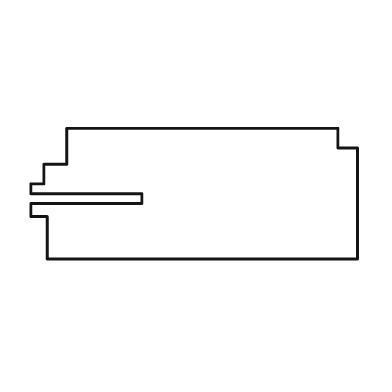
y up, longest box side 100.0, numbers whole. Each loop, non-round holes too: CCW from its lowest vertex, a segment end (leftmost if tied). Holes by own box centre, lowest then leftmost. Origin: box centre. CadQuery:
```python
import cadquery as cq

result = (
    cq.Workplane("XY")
    .moveTo(-45.0, -20.0)
    .lineTo(50.0, -20.0)
    .lineTo(50.0, 14.0)
    .lineTo(44.0, 14.0)
    .lineTo(44.0, 20.0)
    .lineTo(-39.0, 20.0)
    .lineTo(-39.0, 9.0)
    .lineTo(-46.0, 9.0)
    .lineTo(-46.0, 3.0)
    .lineTo(-50.0, 3.0)
    .lineTo(-50.0, 0.0)
    .lineTo(-16.0, 0.0)
    .lineTo(-16.0, -3.0)
    .lineTo(-50.0, -3.0)
    .lineTo(-50.0, -7.0)
    .lineTo(-45.0, -7.0)
    .close()
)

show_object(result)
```